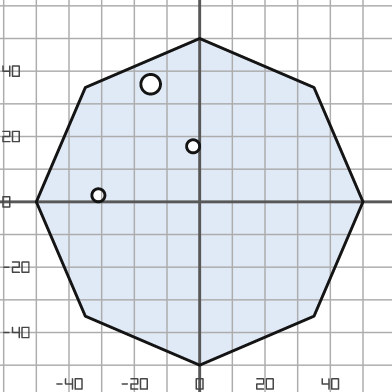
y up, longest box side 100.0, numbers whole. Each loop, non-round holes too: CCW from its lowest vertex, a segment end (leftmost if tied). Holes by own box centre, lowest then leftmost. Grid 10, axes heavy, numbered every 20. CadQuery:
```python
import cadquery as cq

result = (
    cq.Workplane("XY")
    .moveTo(0.0, -50.0)
    .lineTo(35.0, -35.0)
    .lineTo(50.0, 0.0)
    .lineTo(35.0, 35.0)
    .lineTo(0.0, 50.0)
    .lineTo(-35.0, 35.0)
    .lineTo(-50.0, 0.0)
    .lineTo(-35.0, -35.0)
    .close()
    .moveTo(-31.0, 2.0)
    .circle(2.0)
    .moveTo(-2.0, 17.0)
    .circle(2.0)
    .moveTo(-15.0, 36.0)
    .circle(3.0)
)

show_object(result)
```